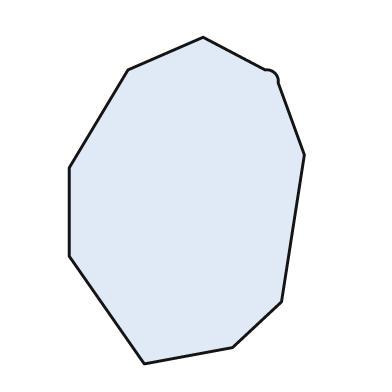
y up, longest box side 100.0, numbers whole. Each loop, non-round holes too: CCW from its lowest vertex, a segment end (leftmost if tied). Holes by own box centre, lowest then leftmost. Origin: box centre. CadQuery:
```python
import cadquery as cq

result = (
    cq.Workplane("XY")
    .moveTo(-13.0, -50.0)
    .lineTo(14.0, -45.0)
    .lineTo(29.0, -31.0)
    .lineTo(36.0, 14.0)
    .lineTo(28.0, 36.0)
    .threePointArc((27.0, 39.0), (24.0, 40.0))
    .lineTo(5.0, 50.0)
    .lineTo(-18.0, 40.0)
    .lineTo(-36.0, 10.0)
    .lineTo(-36.0, -17.0)
    .close()
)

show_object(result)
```